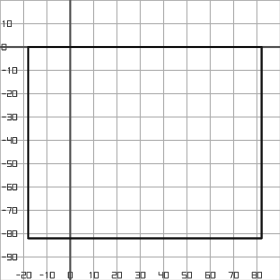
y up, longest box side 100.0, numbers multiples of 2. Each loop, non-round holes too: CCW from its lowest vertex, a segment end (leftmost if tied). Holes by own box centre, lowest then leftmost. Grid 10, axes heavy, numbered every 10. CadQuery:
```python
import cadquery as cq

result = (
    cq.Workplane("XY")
    .moveTo(-18.0, -82.0)
    .lineTo(82.0, -82.0)
    .lineTo(82.0, 0.0)
    .lineTo(-18.0, 0.0)
    .close()
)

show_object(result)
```